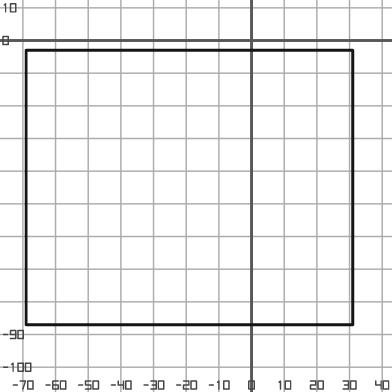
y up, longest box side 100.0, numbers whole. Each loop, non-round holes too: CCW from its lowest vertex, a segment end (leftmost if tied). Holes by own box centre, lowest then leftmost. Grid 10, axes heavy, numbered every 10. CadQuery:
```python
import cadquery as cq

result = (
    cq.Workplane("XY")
    .moveTo(-69.0, -87.0)
    .lineTo(31.0, -87.0)
    .lineTo(31.0, -3.0)
    .lineTo(-69.0, -3.0)
    .close()
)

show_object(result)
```